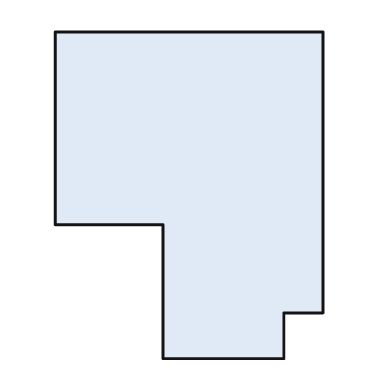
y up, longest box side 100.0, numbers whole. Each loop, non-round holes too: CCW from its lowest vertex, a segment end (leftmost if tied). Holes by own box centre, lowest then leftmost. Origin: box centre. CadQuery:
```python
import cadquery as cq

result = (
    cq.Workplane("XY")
    .moveTo(-8.0, -50.0)
    .lineTo(29.0, -50.0)
    .lineTo(29.0, -36.0)
    .lineTo(41.0, -36.0)
    .lineTo(41.0, 50.0)
    .lineTo(-41.0, 50.0)
    .lineTo(-41.0, -9.0)
    .lineTo(-8.0, -9.0)
    .close()
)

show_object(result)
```